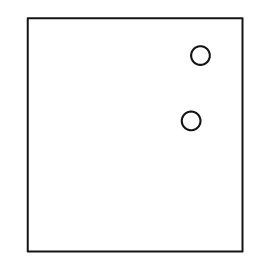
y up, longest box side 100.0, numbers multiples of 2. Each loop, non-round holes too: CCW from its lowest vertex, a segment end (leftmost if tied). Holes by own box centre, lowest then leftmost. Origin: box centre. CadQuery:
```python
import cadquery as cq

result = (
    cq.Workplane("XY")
    .moveTo(-46.0, -50.0)
    .lineTo(46.0, -50.0)
    .lineTo(46.0, 50.0)
    .lineTo(-46.0, 50.0)
    .close()
    .moveTo(24.0, 6.0)
    .circle(4.0)
    .moveTo(28.0, 34.0)
    .circle(4.0)
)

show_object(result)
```